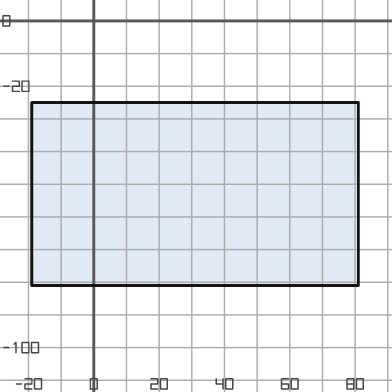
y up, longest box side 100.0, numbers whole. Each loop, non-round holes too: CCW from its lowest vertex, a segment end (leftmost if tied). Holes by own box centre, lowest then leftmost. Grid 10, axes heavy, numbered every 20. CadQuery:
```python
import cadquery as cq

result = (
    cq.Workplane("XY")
    .moveTo(-19.0, -81.0)
    .lineTo(81.0, -81.0)
    .lineTo(81.0, -25.0)
    .lineTo(-19.0, -25.0)
    .close()
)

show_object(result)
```